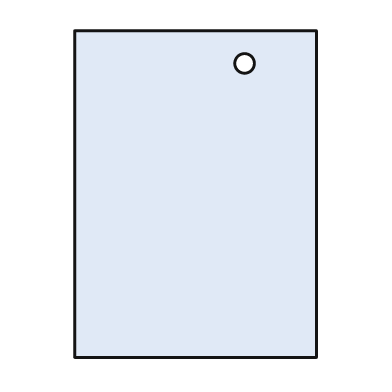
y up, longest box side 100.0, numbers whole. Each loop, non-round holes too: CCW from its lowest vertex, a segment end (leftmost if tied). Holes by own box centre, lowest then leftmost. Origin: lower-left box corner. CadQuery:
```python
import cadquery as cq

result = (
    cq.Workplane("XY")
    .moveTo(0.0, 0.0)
    .lineTo(74.0, 0.0)
    .lineTo(74.0, 100.0)
    .lineTo(0.0, 100.0)
    .close()
    .moveTo(52.0, 90.0)
    .circle(3.0)
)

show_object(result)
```